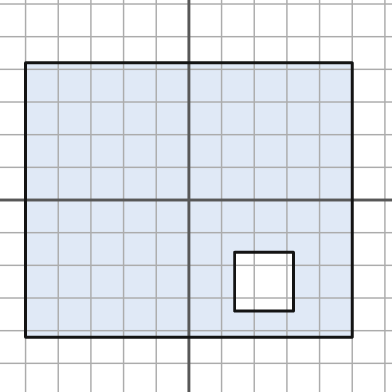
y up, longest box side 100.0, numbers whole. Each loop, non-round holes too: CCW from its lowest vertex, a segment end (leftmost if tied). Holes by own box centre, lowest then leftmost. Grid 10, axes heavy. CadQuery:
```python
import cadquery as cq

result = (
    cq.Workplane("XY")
    .moveTo(-50.0, -42.0)
    .lineTo(50.0, -42.0)
    .lineTo(50.0, 42.0)
    .lineTo(-50.0, 42.0)
    .close()
    .moveTo(14.0, -34.0)
    .lineTo(32.0, -34.0)
    .lineTo(32.0, -16.0)
    .lineTo(14.0, -16.0)
    .close()
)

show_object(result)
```